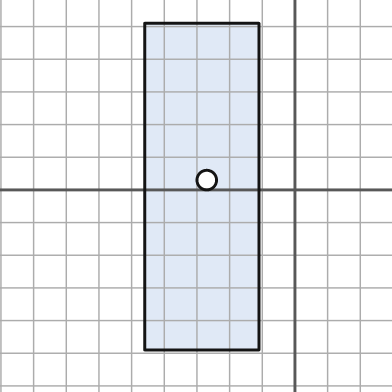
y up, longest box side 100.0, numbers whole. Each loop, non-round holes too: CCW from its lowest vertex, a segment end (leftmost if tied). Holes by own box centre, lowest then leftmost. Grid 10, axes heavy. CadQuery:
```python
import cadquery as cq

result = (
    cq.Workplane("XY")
    .moveTo(-46.0, -49.0)
    .lineTo(-11.0, -49.0)
    .lineTo(-11.0, 51.0)
    .lineTo(-46.0, 51.0)
    .close()
    .moveTo(-27.0, 3.0)
    .circle(3.0)
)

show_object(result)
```